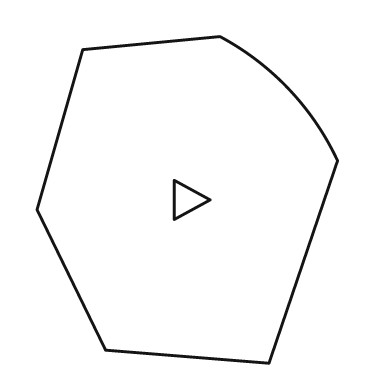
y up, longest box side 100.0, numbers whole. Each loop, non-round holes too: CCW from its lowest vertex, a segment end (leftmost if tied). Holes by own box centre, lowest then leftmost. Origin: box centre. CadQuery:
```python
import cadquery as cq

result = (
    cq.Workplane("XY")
    .moveTo(25.0, -50.0)
    .lineTo(46.0, 12.0)
    .threePointArc((31.0, 34.0), (10.0, 50.0))
    .lineTo(-32.0, 46.0)
    .lineTo(-46.0, -3.0)
    .lineTo(-25.0, -46.0)
    .close()
    .moveTo(-4.0, -6.0)
    .lineTo(7.0, 0.0)
    .lineTo(-4.0, 6.0)
    .close()
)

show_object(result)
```